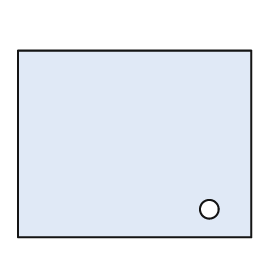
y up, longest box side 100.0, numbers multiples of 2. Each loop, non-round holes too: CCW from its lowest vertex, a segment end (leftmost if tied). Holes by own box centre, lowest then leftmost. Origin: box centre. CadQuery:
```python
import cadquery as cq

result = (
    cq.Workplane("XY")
    .moveTo(-50.0, -40.0)
    .lineTo(50.0, -40.0)
    .lineTo(50.0, 40.0)
    .lineTo(-50.0, 40.0)
    .close()
    .moveTo(32.0, -28.0)
    .circle(4.0)
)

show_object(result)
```